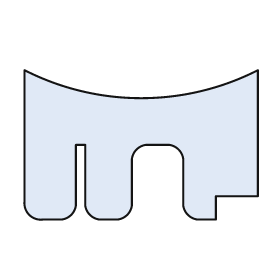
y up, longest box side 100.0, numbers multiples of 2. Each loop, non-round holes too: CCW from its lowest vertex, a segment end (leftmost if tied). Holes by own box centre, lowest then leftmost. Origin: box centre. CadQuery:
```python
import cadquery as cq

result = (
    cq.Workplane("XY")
    .moveTo(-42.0, -32.0)
    .lineTo(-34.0, -32.0)
    .threePointArc((-30.0, -30.0), (-28.0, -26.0))
    .lineTo(-28.0, 0.0)
    .lineTo(-24.0, 0.0)
    .lineTo(-24.0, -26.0)
    .threePointArc((-22.0, -30.0), (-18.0, -32.0))
    .lineTo(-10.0, -32.0)
    .threePointArc((-6.0, -30.0), (-4.0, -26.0))
    .lineTo(-4.0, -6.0)
    .threePointArc((-2.0, -2.0), (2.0, 0.0))
    .lineTo(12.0, 0.0)
    .threePointArc((16.0, -2.0), (18.0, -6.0))
    .lineTo(18.0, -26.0)
    .threePointArc((20.0, -30.0), (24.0, -32.0))
    .lineTo(32.0, -32.0)
    .lineTo(32.0, -22.0)
    .lineTo(50.0, -22.0)
    .lineTo(50.0, 32.0)
    .threePointArc((0.0, 20.0), (-50.0, 32.0))
    .lineTo(-50.0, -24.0)
    .threePointArc((-48.0, -30.0), (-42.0, -32.0))
    .close()
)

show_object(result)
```